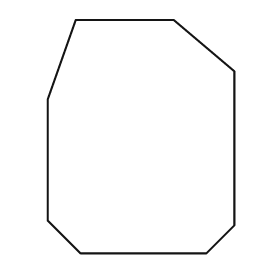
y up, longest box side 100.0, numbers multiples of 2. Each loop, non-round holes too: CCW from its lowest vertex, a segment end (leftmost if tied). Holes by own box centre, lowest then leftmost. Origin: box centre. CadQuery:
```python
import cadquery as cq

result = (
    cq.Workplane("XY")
    .moveTo(-26.0, -50.0)
    .lineTo(28.0, -50.0)
    .lineTo(40.0, -38.0)
    .lineTo(40.0, 28.0)
    .lineTo(14.0, 50.0)
    .lineTo(-28.0, 50.0)
    .lineTo(-40.0, 16.0)
    .lineTo(-40.0, -36.0)
    .close()
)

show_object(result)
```